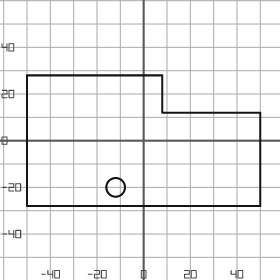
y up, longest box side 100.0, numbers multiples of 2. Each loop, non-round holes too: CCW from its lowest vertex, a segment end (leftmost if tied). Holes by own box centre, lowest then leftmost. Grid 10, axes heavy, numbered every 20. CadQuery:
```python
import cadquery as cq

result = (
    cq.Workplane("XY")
    .moveTo(-50.0, -28.0)
    .lineTo(50.0, -28.0)
    .lineTo(50.0, 12.0)
    .lineTo(8.0, 12.0)
    .lineTo(8.0, 28.0)
    .lineTo(-50.0, 28.0)
    .close()
    .moveTo(-12.0, -20.0)
    .circle(4.0)
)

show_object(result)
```